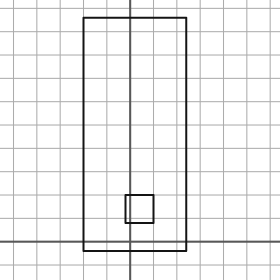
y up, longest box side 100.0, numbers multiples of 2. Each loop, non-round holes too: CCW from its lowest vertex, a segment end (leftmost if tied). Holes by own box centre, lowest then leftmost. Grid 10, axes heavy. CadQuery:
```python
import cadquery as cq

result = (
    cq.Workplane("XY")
    .moveTo(-20.0, -4.0)
    .lineTo(24.0, -4.0)
    .lineTo(24.0, 96.0)
    .lineTo(-20.0, 96.0)
    .close()
    .moveTo(-2.0, 8.0)
    .lineTo(10.0, 8.0)
    .lineTo(10.0, 20.0)
    .lineTo(-2.0, 20.0)
    .close()
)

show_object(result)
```